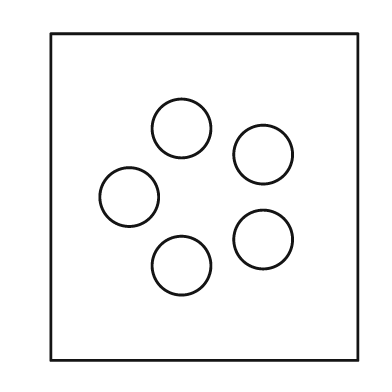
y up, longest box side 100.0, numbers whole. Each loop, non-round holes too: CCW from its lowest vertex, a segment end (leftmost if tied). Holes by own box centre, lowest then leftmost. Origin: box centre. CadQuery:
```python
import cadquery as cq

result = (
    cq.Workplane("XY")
    .moveTo(-47.0, -50.0)
    .lineTo(47.0, -50.0)
    .lineTo(47.0, 50.0)
    .lineTo(-47.0, 50.0)
    .close()
    .moveTo(-7.0, -21.0)
    .circle(9.0)
    .moveTo(18.0, -13.0)
    .circle(9.0)
    .moveTo(-23.0, 0.0)
    .circle(9.0)
    .moveTo(18.0, 13.0)
    .circle(9.0)
    .moveTo(-7.0, 21.0)
    .circle(9.0)
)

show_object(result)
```